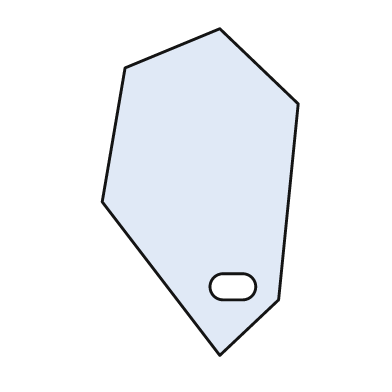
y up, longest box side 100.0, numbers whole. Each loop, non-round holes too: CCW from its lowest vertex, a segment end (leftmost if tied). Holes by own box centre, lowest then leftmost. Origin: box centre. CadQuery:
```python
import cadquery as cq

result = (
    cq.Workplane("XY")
    .moveTo(6.0, -50.0)
    .lineTo(24.0, -33.0)
    .lineTo(30.0, 27.0)
    .lineTo(6.0, 50.0)
    .lineTo(-23.0, 38.0)
    .lineTo(-30.0, -3.0)
    .close()
    .moveTo(7.0, -33.0)
    .lineTo(13.0, -33.0)
    .threePointArc((17.0, -29.0), (13.0, -25.0))
    .lineTo(7.0, -25.0)
    .threePointArc((3.0, -29.0), (7.0, -33.0))
    .close()
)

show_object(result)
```